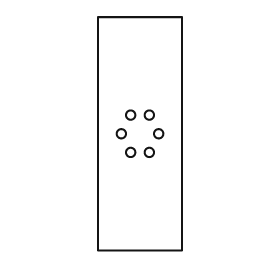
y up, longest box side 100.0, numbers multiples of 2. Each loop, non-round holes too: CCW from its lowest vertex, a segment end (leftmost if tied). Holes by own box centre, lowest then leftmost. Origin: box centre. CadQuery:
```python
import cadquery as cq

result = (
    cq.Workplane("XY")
    .moveTo(-18.0, -50.0)
    .lineTo(18.0, -50.0)
    .lineTo(18.0, 50.0)
    .lineTo(-18.0, 50.0)
    .close()
    .moveTo(-4.0, -8.0)
    .circle(2.0)
    .moveTo(4.0, -8.0)
    .circle(2.0)
    .moveTo(-8.0, 0.0)
    .circle(2.0)
    .moveTo(8.0, 0.0)
    .circle(2.0)
    .moveTo(-4.0, 8.0)
    .circle(2.0)
    .moveTo(4.0, 8.0)
    .circle(2.0)
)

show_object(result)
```